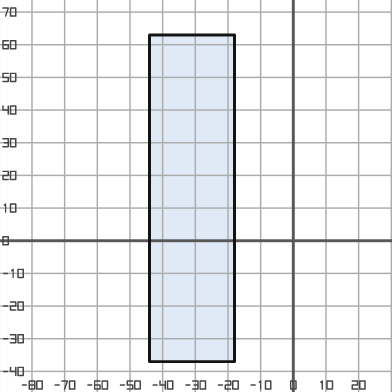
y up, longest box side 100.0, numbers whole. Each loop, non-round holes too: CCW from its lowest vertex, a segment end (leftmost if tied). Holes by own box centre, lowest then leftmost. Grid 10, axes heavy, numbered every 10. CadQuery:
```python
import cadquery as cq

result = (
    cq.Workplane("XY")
    .moveTo(-44.0, -37.0)
    .lineTo(-18.0, -37.0)
    .lineTo(-18.0, 63.0)
    .lineTo(-44.0, 63.0)
    .close()
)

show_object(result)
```